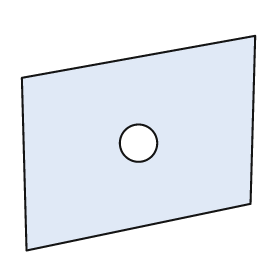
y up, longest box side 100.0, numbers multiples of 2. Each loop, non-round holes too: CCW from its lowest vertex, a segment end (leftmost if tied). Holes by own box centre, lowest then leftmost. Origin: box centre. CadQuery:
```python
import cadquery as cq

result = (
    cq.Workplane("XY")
    .moveTo(-48.0, -46.0)
    .lineTo(48.0, -26.0)
    .lineTo(50.0, 46.0)
    .lineTo(-50.0, 28.0)
    .close()
    .moveTo(0.0, 0.0)
    .circle(8.0)
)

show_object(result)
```